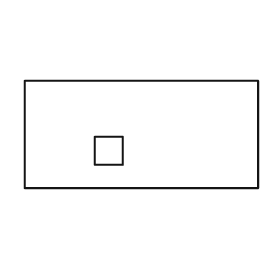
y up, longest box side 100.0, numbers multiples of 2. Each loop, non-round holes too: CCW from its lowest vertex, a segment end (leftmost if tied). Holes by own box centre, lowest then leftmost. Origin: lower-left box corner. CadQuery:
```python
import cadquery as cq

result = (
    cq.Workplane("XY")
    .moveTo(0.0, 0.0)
    .lineTo(100.0, 0.0)
    .lineTo(100.0, 46.0)
    .lineTo(0.0, 46.0)
    .close()
    .moveTo(30.0, 10.0)
    .lineTo(42.0, 10.0)
    .lineTo(42.0, 22.0)
    .lineTo(30.0, 22.0)
    .close()
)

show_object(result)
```